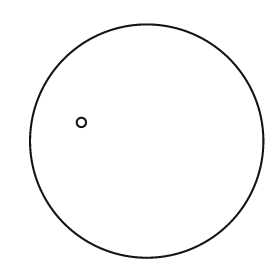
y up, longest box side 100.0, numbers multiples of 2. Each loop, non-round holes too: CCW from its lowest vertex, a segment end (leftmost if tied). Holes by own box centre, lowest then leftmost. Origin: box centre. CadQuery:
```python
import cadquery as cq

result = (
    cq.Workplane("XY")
    .moveTo(0.0, 0.0)
    .circle(50.0)
    .moveTo(-28.0, 8.0)
    .circle(2.0)
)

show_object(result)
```